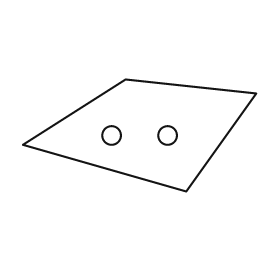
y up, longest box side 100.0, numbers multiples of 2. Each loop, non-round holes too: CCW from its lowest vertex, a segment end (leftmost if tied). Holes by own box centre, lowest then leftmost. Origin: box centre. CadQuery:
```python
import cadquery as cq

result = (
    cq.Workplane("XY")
    .moveTo(20.0, -24.0)
    .lineTo(50.0, 18.0)
    .lineTo(-6.0, 24.0)
    .lineTo(-50.0, -4.0)
    .close()
    .moveTo(-12.0, 0.0)
    .circle(4.0)
    .moveTo(12.0, 0.0)
    .circle(4.0)
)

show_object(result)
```